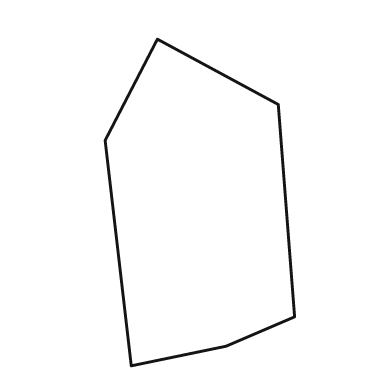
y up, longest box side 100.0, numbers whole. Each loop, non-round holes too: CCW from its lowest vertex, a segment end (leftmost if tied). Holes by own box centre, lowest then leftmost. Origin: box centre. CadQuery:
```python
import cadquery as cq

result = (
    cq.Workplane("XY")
    .moveTo(-21.0, -50.0)
    .lineTo(8.0, -44.0)
    .lineTo(29.0, -35.0)
    .lineTo(24.0, 30.0)
    .lineTo(-13.0, 50.0)
    .lineTo(-29.0, 19.0)
    .close()
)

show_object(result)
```